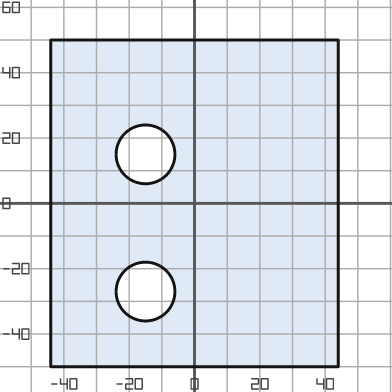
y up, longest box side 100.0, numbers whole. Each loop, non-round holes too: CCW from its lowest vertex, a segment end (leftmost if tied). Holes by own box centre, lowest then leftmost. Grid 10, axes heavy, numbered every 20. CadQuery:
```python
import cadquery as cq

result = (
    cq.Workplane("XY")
    .moveTo(-44.0, -50.0)
    .lineTo(44.0, -50.0)
    .lineTo(44.0, 50.0)
    .lineTo(-44.0, 50.0)
    .close()
    .moveTo(-15.0, -27.0)
    .circle(9.0)
    .moveTo(-15.0, 15.0)
    .circle(9.0)
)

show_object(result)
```